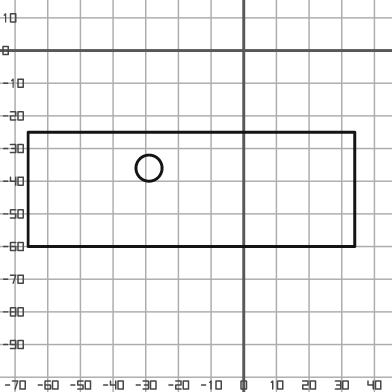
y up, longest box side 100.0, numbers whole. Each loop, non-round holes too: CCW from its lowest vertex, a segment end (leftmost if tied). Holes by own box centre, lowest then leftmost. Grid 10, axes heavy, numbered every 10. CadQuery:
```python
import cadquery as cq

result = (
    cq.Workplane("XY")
    .moveTo(-66.0, -60.0)
    .lineTo(34.0, -60.0)
    .lineTo(34.0, -25.0)
    .lineTo(-66.0, -25.0)
    .close()
    .moveTo(-29.0, -36.0)
    .circle(4.0)
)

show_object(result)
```